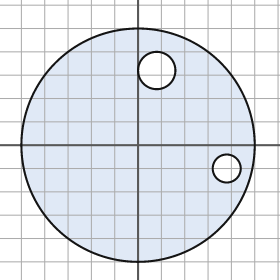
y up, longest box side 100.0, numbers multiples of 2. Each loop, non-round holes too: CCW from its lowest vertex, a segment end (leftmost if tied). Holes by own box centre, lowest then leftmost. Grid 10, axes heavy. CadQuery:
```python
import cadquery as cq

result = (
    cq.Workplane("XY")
    .moveTo(0.0, 0.0)
    .circle(50.0)
    .moveTo(38.0, -10.0)
    .circle(6.0)
    .moveTo(8.0, 32.0)
    .circle(8.0)
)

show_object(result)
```